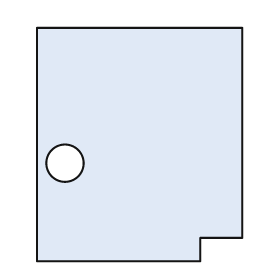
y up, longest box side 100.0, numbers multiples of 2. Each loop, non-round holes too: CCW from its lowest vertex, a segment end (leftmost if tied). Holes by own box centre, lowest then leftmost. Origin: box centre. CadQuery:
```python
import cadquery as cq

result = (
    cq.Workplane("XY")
    .moveTo(-44.0, -50.0)
    .lineTo(26.0, -50.0)
    .lineTo(26.0, -40.0)
    .lineTo(44.0, -40.0)
    .lineTo(44.0, 50.0)
    .lineTo(-44.0, 50.0)
    .close()
    .moveTo(-32.0, -8.0)
    .circle(8.0)
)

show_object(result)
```